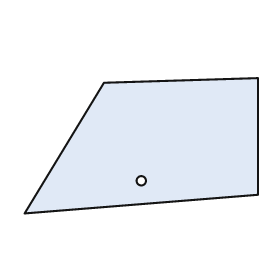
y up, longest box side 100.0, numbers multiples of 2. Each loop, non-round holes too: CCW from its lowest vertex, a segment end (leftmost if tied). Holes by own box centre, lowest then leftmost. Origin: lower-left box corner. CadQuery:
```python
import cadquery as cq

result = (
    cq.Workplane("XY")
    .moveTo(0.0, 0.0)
    .lineTo(100.0, 8.0)
    .lineTo(100.0, 58.0)
    .lineTo(34.0, 56.0)
    .close()
    .moveTo(50.0, 14.0)
    .circle(2.0)
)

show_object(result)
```